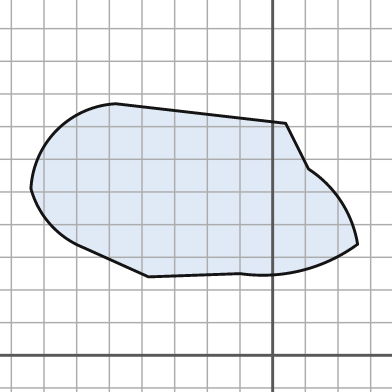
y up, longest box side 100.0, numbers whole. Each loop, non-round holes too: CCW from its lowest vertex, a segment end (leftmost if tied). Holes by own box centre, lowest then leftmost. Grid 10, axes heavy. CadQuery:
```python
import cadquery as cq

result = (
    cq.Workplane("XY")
    .moveTo(-38.0, 24.0)
    .lineTo(-10.0, 25.0)
    .threePointArc((9.0, 26.0), (26.0, 34.0))
    .threePointArc((21.0, 47.0), (11.0, 57.0))
    .lineTo(4.0, 71.0)
    .lineTo(-48.0, 77.0)
    .threePointArc((-66.0, 69.0), (-74.0, 51.0))
    .threePointArc((-68.0, 40.0), (-58.0, 33.0))
    .close()
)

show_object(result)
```